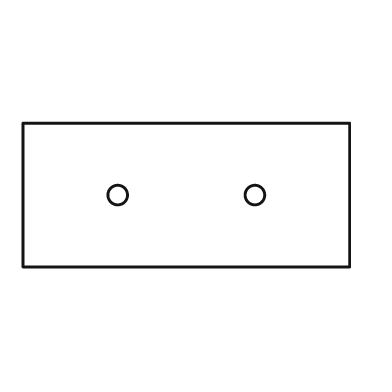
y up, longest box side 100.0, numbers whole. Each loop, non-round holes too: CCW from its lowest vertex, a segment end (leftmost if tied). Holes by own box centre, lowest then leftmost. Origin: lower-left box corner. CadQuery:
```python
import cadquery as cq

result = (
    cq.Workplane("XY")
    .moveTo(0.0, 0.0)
    .lineTo(100.0, 0.0)
    .lineTo(100.0, 44.0)
    .lineTo(0.0, 44.0)
    .close()
    .moveTo(29.0, 22.0)
    .circle(3.0)
    .moveTo(71.0, 22.0)
    .circle(3.0)
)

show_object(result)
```